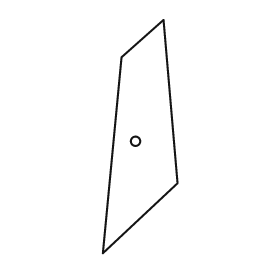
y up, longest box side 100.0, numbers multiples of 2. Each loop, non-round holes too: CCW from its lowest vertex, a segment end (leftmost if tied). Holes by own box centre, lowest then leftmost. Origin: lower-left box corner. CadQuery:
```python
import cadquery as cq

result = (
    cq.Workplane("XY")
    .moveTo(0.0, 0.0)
    .lineTo(32.0, 30.0)
    .lineTo(26.0, 100.0)
    .lineTo(8.0, 84.0)
    .close()
    .moveTo(14.0, 48.0)
    .circle(2.0)
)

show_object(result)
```